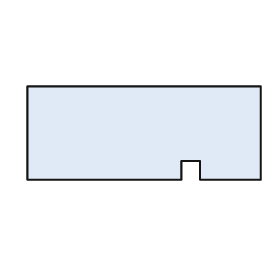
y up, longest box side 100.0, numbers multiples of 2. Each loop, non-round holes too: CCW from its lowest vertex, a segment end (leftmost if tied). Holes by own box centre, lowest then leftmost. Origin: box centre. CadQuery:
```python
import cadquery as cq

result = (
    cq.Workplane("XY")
    .moveTo(-50.0, -20.0)
    .lineTo(16.0, -20.0)
    .lineTo(16.0, -12.0)
    .lineTo(24.0, -12.0)
    .lineTo(24.0, -20.0)
    .lineTo(50.0, -20.0)
    .lineTo(50.0, 20.0)
    .lineTo(-50.0, 20.0)
    .close()
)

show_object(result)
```